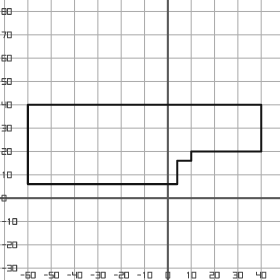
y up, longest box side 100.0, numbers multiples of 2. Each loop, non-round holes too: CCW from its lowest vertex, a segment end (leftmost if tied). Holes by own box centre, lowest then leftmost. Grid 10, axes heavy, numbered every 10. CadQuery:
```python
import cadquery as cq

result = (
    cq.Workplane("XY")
    .moveTo(-60.0, 6.0)
    .lineTo(4.0, 6.0)
    .lineTo(4.0, 16.0)
    .lineTo(10.0, 16.0)
    .lineTo(10.0, 20.0)
    .lineTo(40.0, 20.0)
    .lineTo(40.0, 40.0)
    .lineTo(-60.0, 40.0)
    .close()
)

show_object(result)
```